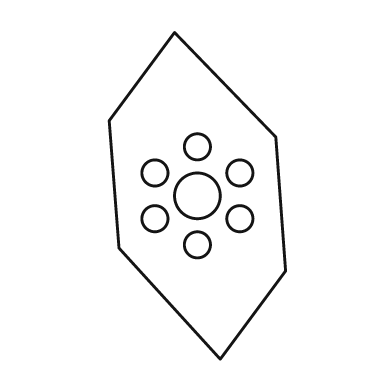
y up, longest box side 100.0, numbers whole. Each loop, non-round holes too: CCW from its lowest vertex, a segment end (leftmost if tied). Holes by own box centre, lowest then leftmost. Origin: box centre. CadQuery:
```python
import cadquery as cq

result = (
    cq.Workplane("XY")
    .moveTo(7.0, -50.0)
    .lineTo(27.0, -23.0)
    .lineTo(24.0, 18.0)
    .lineTo(-7.0, 50.0)
    .lineTo(-27.0, 23.0)
    .lineTo(-24.0, -16.0)
    .close()
    .moveTo(0.0, -15.0)
    .circle(4.0)
    .moveTo(-13.0, -7.0)
    .circle(4.0)
    .moveTo(13.0, -7.0)
    .circle(4.0)
    .moveTo(0.0, 0.0)
    .circle(7.0)
    .moveTo(-13.0, 7.0)
    .circle(4.0)
    .moveTo(13.0, 7.0)
    .circle(4.0)
    .moveTo(0.0, 15.0)
    .circle(4.0)
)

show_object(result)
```